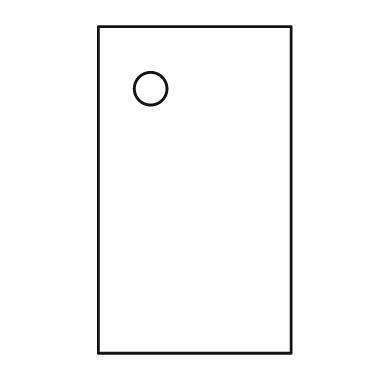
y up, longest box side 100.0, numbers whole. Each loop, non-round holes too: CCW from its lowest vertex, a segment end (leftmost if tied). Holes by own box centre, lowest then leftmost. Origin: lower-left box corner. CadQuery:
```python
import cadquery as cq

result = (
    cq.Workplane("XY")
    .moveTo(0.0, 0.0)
    .lineTo(59.0, 0.0)
    .lineTo(59.0, 100.0)
    .lineTo(0.0, 100.0)
    .close()
    .moveTo(16.0, 81.0)
    .circle(5.0)
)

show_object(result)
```